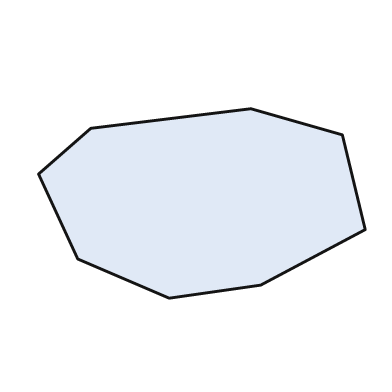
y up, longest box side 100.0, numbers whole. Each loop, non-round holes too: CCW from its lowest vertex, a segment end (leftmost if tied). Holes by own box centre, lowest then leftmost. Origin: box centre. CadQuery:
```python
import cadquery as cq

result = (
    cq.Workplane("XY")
    .moveTo(-10.0, -29.0)
    .lineTo(18.0, -25.0)
    .lineTo(50.0, -8.0)
    .lineTo(43.0, 21.0)
    .lineTo(15.0, 29.0)
    .lineTo(-34.0, 23.0)
    .lineTo(-50.0, 9.0)
    .lineTo(-38.0, -17.0)
    .close()
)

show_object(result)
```